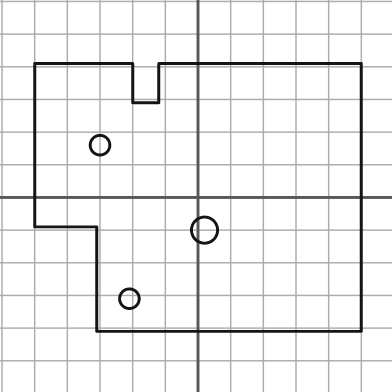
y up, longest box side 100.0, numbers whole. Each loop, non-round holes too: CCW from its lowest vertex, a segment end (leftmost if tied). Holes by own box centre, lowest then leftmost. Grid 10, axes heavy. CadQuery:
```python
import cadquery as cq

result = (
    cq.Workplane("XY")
    .moveTo(-31.0, -41.0)
    .lineTo(50.0, -41.0)
    .lineTo(50.0, 41.0)
    .lineTo(-12.0, 41.0)
    .lineTo(-12.0, 29.0)
    .lineTo(-20.0, 29.0)
    .lineTo(-20.0, 41.0)
    .lineTo(-50.0, 41.0)
    .lineTo(-50.0, -9.0)
    .lineTo(-31.0, -9.0)
    .close()
    .moveTo(-21.0, -31.0)
    .circle(3.0)
    .moveTo(2.0, -10.0)
    .circle(4.0)
    .moveTo(-30.0, 16.0)
    .circle(3.0)
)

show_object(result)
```